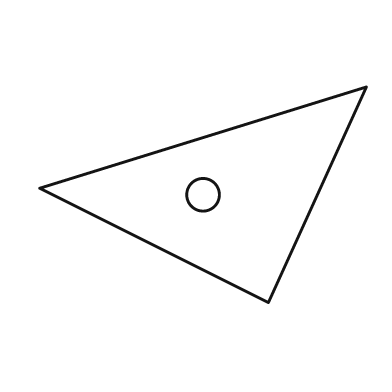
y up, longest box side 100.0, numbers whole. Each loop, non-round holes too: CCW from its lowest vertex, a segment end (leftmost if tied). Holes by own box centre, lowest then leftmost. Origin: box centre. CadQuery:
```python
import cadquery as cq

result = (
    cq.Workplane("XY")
    .moveTo(20.0, -33.0)
    .lineTo(50.0, 33.0)
    .lineTo(-50.0, 2.0)
    .close()
    .moveTo(0.0, 0.0)
    .circle(5.0)
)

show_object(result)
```